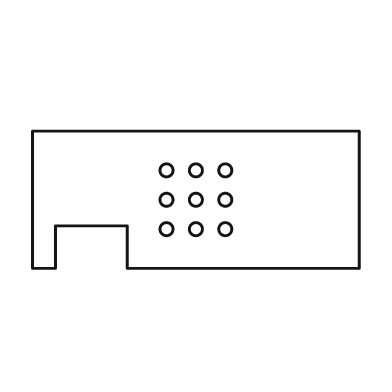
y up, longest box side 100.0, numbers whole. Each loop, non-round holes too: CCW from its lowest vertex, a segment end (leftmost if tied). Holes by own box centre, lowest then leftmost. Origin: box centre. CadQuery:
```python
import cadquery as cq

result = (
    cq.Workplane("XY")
    .moveTo(-50.0, -21.0)
    .lineTo(-43.0, -21.0)
    .lineTo(-43.0, -8.0)
    .lineTo(-21.0, -8.0)
    .lineTo(-21.0, -21.0)
    .lineTo(50.0, -21.0)
    .lineTo(50.0, 21.0)
    .lineTo(-50.0, 21.0)
    .close()
    .moveTo(-9.0, -9.0)
    .circle(2.0)
    .moveTo(0.0, -9.0)
    .circle(2.0)
    .moveTo(9.0, -9.0)
    .circle(2.0)
    .moveTo(-9.0, 0.0)
    .circle(2.0)
    .moveTo(0.0, 0.0)
    .circle(2.0)
    .moveTo(9.0, 0.0)
    .circle(2.0)
    .moveTo(-9.0, 9.0)
    .circle(2.0)
    .moveTo(0.0, 9.0)
    .circle(2.0)
    .moveTo(9.0, 9.0)
    .circle(2.0)
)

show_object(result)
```